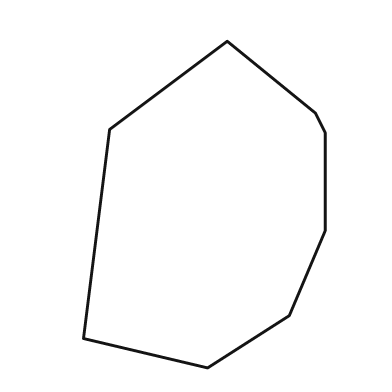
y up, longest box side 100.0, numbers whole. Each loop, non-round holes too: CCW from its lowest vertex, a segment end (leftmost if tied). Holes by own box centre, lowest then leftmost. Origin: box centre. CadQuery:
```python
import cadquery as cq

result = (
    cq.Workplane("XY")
    .moveTo(1.0, -50.0)
    .lineTo(26.0, -34.0)
    .lineTo(37.0, -8.0)
    .lineTo(37.0, 22.0)
    .lineTo(34.0, 28.0)
    .lineTo(7.0, 50.0)
    .lineTo(-29.0, 23.0)
    .lineTo(-37.0, -41.0)
    .close()
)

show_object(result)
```